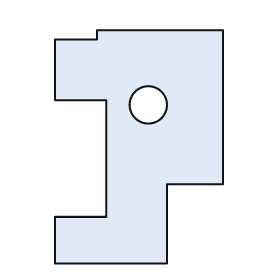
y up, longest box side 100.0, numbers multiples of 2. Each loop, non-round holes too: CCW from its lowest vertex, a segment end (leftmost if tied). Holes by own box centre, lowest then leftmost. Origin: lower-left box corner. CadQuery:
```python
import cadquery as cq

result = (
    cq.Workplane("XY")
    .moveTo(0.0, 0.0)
    .lineTo(48.0, 0.0)
    .lineTo(48.0, 34.0)
    .lineTo(72.0, 34.0)
    .lineTo(72.0, 100.0)
    .lineTo(18.0, 100.0)
    .lineTo(18.0, 96.0)
    .lineTo(0.0, 96.0)
    .lineTo(0.0, 70.0)
    .lineTo(22.0, 70.0)
    .lineTo(22.0, 20.0)
    .lineTo(0.0, 20.0)
    .close()
    .moveTo(40.0, 68.0)
    .circle(8.0)
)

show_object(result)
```